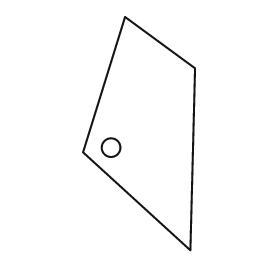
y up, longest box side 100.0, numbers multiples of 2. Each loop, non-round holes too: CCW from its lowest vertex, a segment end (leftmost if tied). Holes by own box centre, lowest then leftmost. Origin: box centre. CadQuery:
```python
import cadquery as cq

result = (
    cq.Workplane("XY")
    .moveTo(22.0, -50.0)
    .lineTo(24.0, 28.0)
    .lineTo(-6.0, 50.0)
    .lineTo(-24.0, -8.0)
    .close()
    .moveTo(-12.0, -6.0)
    .circle(4.0)
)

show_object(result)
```